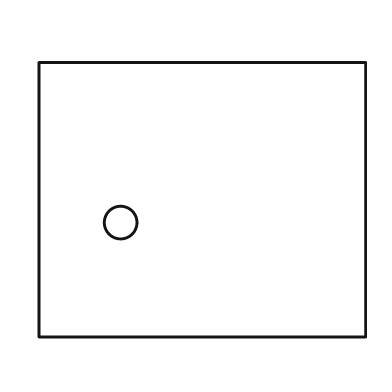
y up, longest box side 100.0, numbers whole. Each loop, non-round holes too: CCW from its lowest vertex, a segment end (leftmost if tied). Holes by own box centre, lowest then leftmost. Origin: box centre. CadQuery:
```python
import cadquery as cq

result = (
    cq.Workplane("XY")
    .moveTo(-50.0, -42.0)
    .lineTo(50.0, -42.0)
    .lineTo(50.0, 42.0)
    .lineTo(-50.0, 42.0)
    .close()
    .moveTo(-25.0, -7.0)
    .circle(5.0)
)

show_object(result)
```